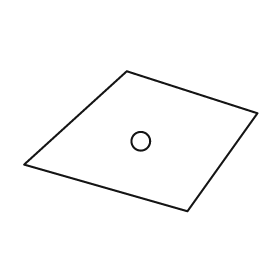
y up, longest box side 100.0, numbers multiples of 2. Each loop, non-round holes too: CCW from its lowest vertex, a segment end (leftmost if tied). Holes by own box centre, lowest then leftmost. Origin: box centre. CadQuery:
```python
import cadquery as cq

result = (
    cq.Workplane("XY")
    .moveTo(20.0, -30.0)
    .lineTo(50.0, 12.0)
    .lineTo(-6.0, 30.0)
    .lineTo(-50.0, -10.0)
    .close()
    .moveTo(0.0, 0.0)
    .circle(4.0)
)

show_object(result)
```